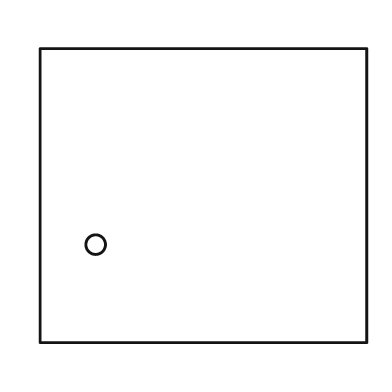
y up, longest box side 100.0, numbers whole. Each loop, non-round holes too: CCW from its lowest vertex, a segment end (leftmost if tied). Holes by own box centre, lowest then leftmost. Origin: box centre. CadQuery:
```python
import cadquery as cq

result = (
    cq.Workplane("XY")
    .moveTo(-50.0, -45.0)
    .lineTo(50.0, -45.0)
    .lineTo(50.0, 45.0)
    .lineTo(-50.0, 45.0)
    .close()
    .moveTo(-33.0, -15.0)
    .circle(3.0)
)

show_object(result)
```